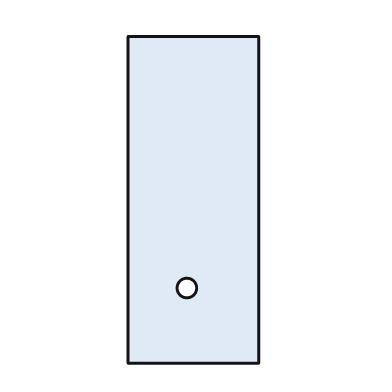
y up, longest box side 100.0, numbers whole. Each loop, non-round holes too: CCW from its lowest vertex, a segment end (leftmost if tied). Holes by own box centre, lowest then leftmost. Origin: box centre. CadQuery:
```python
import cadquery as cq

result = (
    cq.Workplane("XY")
    .moveTo(-20.0, -50.0)
    .lineTo(20.0, -50.0)
    .lineTo(20.0, 50.0)
    .lineTo(-20.0, 50.0)
    .close()
    .moveTo(-2.0, -27.0)
    .circle(3.0)
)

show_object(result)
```